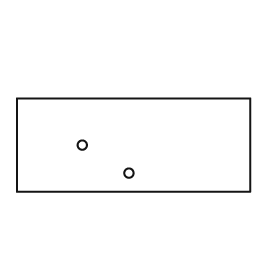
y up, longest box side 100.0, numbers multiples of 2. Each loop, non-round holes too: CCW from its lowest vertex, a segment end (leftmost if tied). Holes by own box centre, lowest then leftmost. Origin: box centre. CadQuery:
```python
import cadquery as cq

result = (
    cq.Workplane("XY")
    .moveTo(-50.0, -20.0)
    .lineTo(50.0, -20.0)
    .lineTo(50.0, 20.0)
    .lineTo(-50.0, 20.0)
    .close()
    .moveTo(-2.0, -12.0)
    .circle(2.0)
    .moveTo(-22.0, 0.0)
    .circle(2.0)
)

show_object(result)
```